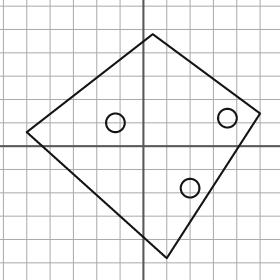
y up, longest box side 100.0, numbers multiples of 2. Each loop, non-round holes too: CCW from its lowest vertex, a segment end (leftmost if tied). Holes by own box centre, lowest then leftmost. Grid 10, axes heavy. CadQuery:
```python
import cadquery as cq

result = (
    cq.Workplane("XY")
    .moveTo(10.0, -48.0)
    .lineTo(50.0, 14.0)
    .lineTo(4.0, 48.0)
    .lineTo(-50.0, 6.0)
    .close()
    .moveTo(20.0, -18.0)
    .circle(4.0)
    .moveTo(-12.0, 10.0)
    .circle(4.0)
    .moveTo(36.0, 12.0)
    .circle(4.0)
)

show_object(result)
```